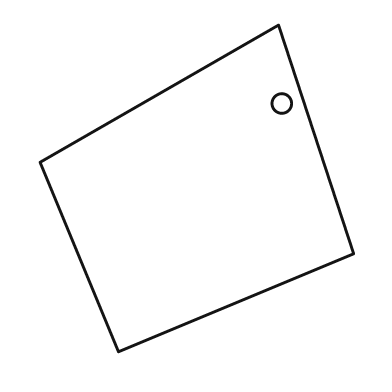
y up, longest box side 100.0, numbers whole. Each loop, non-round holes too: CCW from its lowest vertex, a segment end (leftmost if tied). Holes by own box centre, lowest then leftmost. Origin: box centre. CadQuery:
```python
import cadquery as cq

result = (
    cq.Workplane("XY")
    .moveTo(-24.0, -50.0)
    .lineTo(48.0, -20.0)
    .lineTo(25.0, 50.0)
    .lineTo(-48.0, 8.0)
    .close()
    .moveTo(26.0, 26.0)
    .circle(3.0)
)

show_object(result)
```